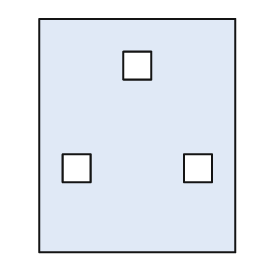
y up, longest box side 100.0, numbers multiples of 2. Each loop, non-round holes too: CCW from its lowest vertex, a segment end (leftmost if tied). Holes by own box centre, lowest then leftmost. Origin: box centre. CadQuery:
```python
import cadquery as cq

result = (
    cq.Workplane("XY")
    .moveTo(-42.0, -50.0)
    .lineTo(42.0, -50.0)
    .lineTo(42.0, 50.0)
    .lineTo(-42.0, 50.0)
    .close()
    .moveTo(-32.0, -20.0)
    .lineTo(-20.0, -20.0)
    .lineTo(-20.0, -8.0)
    .lineTo(-32.0, -8.0)
    .close()
    .moveTo(20.0, -20.0)
    .lineTo(32.0, -20.0)
    .lineTo(32.0, -8.0)
    .lineTo(20.0, -8.0)
    .close()
    .moveTo(-6.0, 24.0)
    .lineTo(6.0, 24.0)
    .lineTo(6.0, 36.0)
    .lineTo(-6.0, 36.0)
    .close()
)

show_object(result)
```